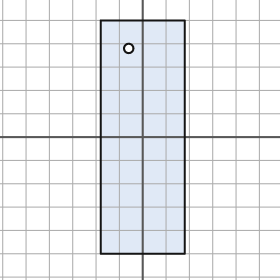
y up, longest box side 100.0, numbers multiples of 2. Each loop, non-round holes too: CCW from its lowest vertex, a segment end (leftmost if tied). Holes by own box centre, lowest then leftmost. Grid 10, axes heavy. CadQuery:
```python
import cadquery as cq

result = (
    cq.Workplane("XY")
    .moveTo(-18.0, -50.0)
    .lineTo(18.0, -50.0)
    .lineTo(18.0, 50.0)
    .lineTo(-18.0, 50.0)
    .close()
    .moveTo(-6.0, 38.0)
    .circle(2.0)
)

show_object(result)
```